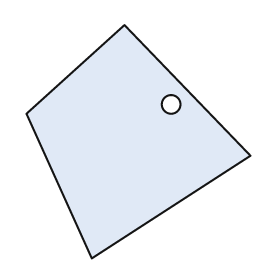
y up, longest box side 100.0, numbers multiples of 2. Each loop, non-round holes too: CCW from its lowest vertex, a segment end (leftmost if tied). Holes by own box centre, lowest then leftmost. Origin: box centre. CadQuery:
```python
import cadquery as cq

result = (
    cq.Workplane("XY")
    .moveTo(-20.0, -50.0)
    .lineTo(48.0, -6.0)
    .lineTo(-6.0, 50.0)
    .lineTo(-48.0, 12.0)
    .close()
    .moveTo(14.0, 16.0)
    .circle(4.0)
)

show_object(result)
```